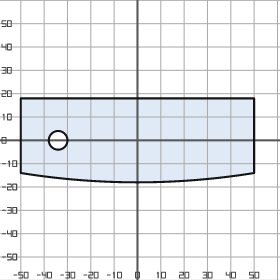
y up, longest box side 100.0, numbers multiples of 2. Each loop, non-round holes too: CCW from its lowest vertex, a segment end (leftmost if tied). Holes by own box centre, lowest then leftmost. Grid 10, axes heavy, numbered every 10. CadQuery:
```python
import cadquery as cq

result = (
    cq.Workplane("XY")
    .moveTo(-50.0, -14.0)
    .threePointArc((0.0, -18.0), (50.0, -14.0))
    .lineTo(50.0, 18.0)
    .lineTo(-50.0, 18.0)
    .close()
    .moveTo(-34.0, 0.0)
    .circle(4.0)
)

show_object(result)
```